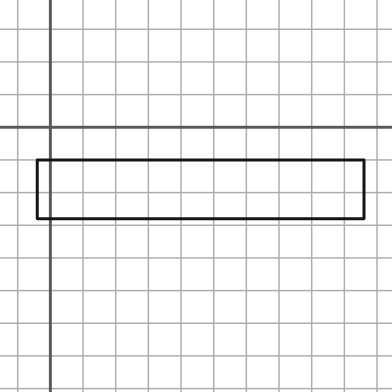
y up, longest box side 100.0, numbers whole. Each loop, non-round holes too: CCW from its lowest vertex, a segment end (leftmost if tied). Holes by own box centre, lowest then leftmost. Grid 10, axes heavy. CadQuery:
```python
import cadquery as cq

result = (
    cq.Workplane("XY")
    .moveTo(-4.0, -28.0)
    .lineTo(96.0, -28.0)
    .lineTo(96.0, -10.0)
    .lineTo(-4.0, -10.0)
    .close()
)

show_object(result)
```